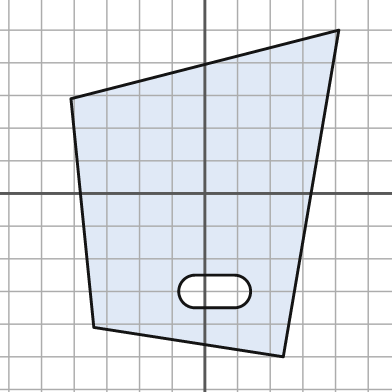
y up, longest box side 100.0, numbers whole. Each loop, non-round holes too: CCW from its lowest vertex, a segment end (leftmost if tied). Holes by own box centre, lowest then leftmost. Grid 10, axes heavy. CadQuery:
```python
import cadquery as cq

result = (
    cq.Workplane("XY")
    .moveTo(24.0, -50.0)
    .lineTo(41.0, 50.0)
    .lineTo(-41.0, 29.0)
    .lineTo(-34.0, -41.0)
    .close()
    .moveTo(-3.0, -35.0)
    .lineTo(9.0, -35.0)
    .threePointArc((14.0, -30.0), (9.0, -25.0))
    .lineTo(-3.0, -25.0)
    .threePointArc((-8.0, -30.0), (-3.0, -35.0))
    .close()
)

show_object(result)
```